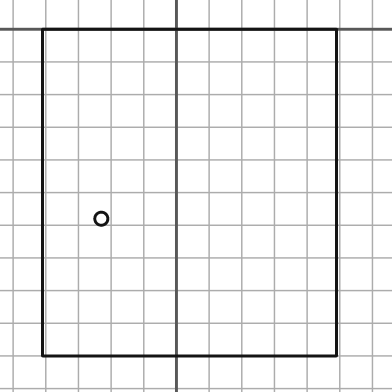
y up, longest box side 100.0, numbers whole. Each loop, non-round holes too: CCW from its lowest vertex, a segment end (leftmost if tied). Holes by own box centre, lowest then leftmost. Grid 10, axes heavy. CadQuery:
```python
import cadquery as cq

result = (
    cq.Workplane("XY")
    .moveTo(-41.0, -100.0)
    .lineTo(49.0, -100.0)
    .lineTo(49.0, 0.0)
    .lineTo(-41.0, 0.0)
    .close()
    .moveTo(-23.0, -58.0)
    .circle(2.0)
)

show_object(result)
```